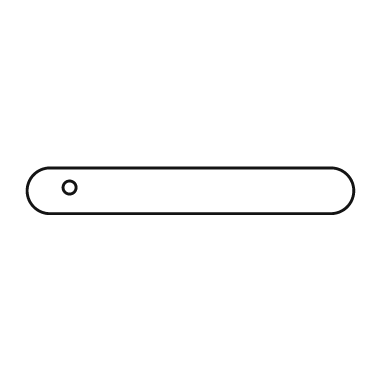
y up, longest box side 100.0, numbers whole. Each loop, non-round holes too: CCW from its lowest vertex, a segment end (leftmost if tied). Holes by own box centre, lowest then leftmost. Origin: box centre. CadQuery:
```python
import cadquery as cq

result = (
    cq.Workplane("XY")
    .moveTo(-43.0, -7.0)
    .lineTo(43.0, -7.0)
    .threePointArc((50.0, 0.0), (43.0, 7.0))
    .lineTo(-43.0, 7.0)
    .threePointArc((-50.0, 0.0), (-43.0, -7.0))
    .close()
    .moveTo(-37.0, 1.0)
    .circle(2.0)
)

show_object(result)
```